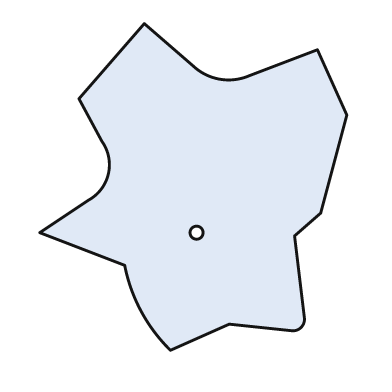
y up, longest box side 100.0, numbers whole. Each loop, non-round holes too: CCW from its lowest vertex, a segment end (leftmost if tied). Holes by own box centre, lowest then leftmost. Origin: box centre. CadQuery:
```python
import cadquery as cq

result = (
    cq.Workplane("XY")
    .moveTo(-7.0, -50.0)
    .lineTo(11.0, -42.0)
    .lineTo(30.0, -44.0)
    .threePointArc((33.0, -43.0), (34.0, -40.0))
    .lineTo(31.0, -15.0)
    .lineTo(39.0, -8.0)
    .lineTo(47.0, 22.0)
    .lineTo(38.0, 42.0)
    .lineTo(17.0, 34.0)
    .threePointArc((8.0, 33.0), (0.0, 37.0))
    .lineTo(-15.0, 50.0)
    .lineTo(-35.0, 27.0)
    .lineTo(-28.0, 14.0)
    .threePointArc((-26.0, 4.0), (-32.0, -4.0))
    .lineTo(-47.0, -14.0)
    .lineTo(-21.0, -24.0)
    .threePointArc((-16.0, -38.0), (-7.0, -50.0))
    .close()
    .moveTo(1.0, -14.0)
    .circle(2.0)
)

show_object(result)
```